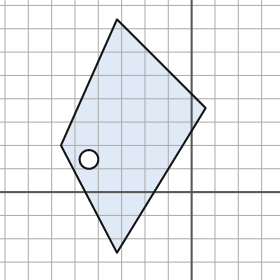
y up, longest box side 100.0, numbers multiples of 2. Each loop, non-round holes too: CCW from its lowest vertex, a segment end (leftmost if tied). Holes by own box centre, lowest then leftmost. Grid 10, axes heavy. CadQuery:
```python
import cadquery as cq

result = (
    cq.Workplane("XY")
    .moveTo(-32.0, -26.0)
    .lineTo(6.0, 36.0)
    .lineTo(-32.0, 74.0)
    .lineTo(-56.0, 20.0)
    .close()
    .moveTo(-44.0, 14.0)
    .circle(4.0)
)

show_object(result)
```